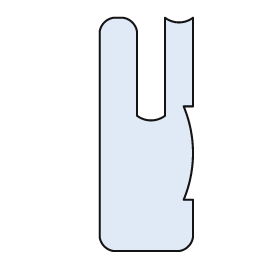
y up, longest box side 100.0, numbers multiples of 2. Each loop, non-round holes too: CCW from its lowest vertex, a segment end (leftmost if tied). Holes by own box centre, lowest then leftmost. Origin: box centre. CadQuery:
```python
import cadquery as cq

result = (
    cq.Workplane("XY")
    .moveTo(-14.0, -50.0)
    .lineTo(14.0, -50.0)
    .threePointArc((18.0, -48.0), (20.0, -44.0))
    .lineTo(20.0, -28.0)
    .lineTo(16.0, -28.0)
    .threePointArc((20.0, -8.0), (16.0, 12.0))
    .lineTo(20.0, 12.0)
    .lineTo(20.0, 50.0)
    .threePointArc((14.0, 48.0), (8.0, 50.0))
    .lineTo(8.0, 8.0)
    .threePointArc((2.0, 6.0), (-4.0, 8.0))
    .lineTo(-4.0, 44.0)
    .threePointArc((-6.0, 48.0), (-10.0, 50.0))
    .lineTo(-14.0, 50.0)
    .threePointArc((-18.0, 48.0), (-20.0, 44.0))
    .lineTo(-20.0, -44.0)
    .threePointArc((-18.0, -48.0), (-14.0, -50.0))
    .close()
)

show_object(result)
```